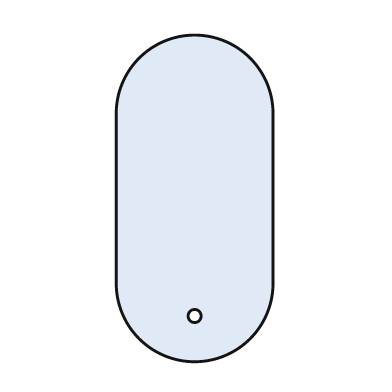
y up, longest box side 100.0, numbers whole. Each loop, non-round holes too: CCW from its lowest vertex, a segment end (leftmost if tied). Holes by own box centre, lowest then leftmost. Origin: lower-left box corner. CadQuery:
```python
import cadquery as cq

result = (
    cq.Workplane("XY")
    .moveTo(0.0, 24.0)
    .threePointArc((24.0, 0.0), (48.0, 24.0))
    .lineTo(48.0, 76.0)
    .threePointArc((24.0, 100.0), (0.0, 76.0))
    .close()
    .moveTo(24.0, 14.0)
    .circle(2.0)
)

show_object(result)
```